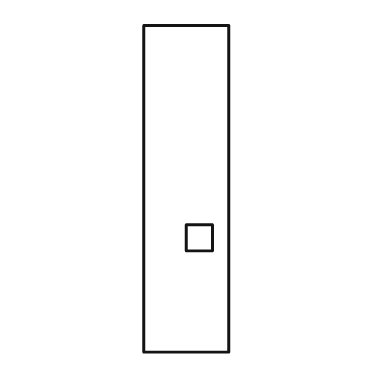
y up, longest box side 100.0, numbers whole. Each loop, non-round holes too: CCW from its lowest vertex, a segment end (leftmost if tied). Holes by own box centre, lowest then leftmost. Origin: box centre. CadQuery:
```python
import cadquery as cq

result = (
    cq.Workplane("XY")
    .moveTo(-13.0, -50.0)
    .lineTo(13.0, -50.0)
    .lineTo(13.0, 50.0)
    .lineTo(-13.0, 50.0)
    .close()
    .moveTo(0.0, -19.0)
    .lineTo(8.0, -19.0)
    .lineTo(8.0, -11.0)
    .lineTo(0.0, -11.0)
    .close()
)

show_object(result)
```